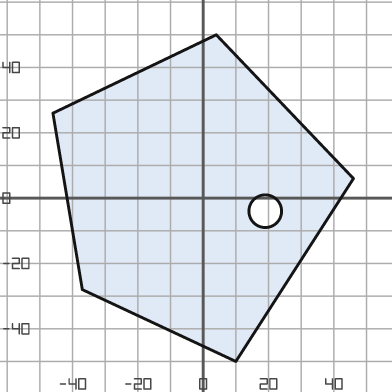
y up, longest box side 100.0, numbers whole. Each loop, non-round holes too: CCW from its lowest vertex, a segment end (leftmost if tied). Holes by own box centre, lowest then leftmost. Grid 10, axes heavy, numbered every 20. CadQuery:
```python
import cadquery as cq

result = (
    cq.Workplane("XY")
    .moveTo(10.0, -50.0)
    .lineTo(46.0, 6.0)
    .lineTo(4.0, 50.0)
    .lineTo(-46.0, 26.0)
    .lineTo(-37.0, -28.0)
    .close()
    .moveTo(19.0, -4.0)
    .circle(5.0)
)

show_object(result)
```